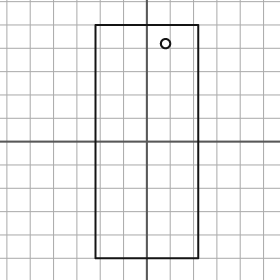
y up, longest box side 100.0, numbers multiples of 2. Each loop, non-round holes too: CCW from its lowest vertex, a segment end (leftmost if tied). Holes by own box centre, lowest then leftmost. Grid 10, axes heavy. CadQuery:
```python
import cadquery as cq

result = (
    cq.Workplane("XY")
    .moveTo(-22.0, -50.0)
    .lineTo(22.0, -50.0)
    .lineTo(22.0, 50.0)
    .lineTo(-22.0, 50.0)
    .close()
    .moveTo(8.0, 42.0)
    .circle(2.0)
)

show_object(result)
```